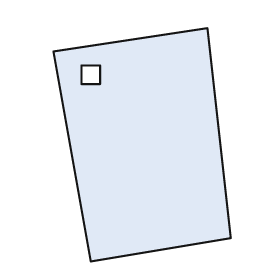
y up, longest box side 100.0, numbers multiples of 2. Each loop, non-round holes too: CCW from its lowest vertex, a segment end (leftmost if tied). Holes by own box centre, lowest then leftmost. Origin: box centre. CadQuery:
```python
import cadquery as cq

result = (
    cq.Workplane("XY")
    .moveTo(-22.0, -50.0)
    .lineTo(38.0, -40.0)
    .lineTo(28.0, 50.0)
    .lineTo(-38.0, 40.0)
    .close()
    .moveTo(-26.0, 26.0)
    .lineTo(-18.0, 26.0)
    .lineTo(-18.0, 34.0)
    .lineTo(-26.0, 34.0)
    .close()
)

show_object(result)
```